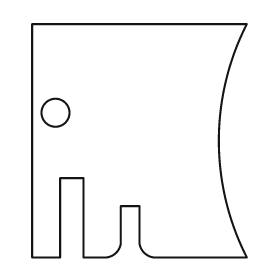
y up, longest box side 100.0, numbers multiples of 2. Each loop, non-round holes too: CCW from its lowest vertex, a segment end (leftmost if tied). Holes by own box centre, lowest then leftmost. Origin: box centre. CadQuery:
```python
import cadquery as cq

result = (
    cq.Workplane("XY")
    .moveTo(-46.0, -50.0)
    .lineTo(-34.0, -50.0)
    .lineTo(-34.0, -16.0)
    .lineTo(-24.0, -16.0)
    .lineTo(-24.0, -50.0)
    .lineTo(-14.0, -50.0)
    .threePointArc((-10.0, -48.0), (-8.0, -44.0))
    .lineTo(-8.0, -28.0)
    .lineTo(0.0, -28.0)
    .lineTo(0.0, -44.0)
    .threePointArc((2.0, -48.0), (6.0, -50.0))
    .lineTo(46.0, -50.0)
    .threePointArc((34.0, 0.0), (46.0, 50.0))
    .lineTo(-46.0, 50.0)
    .close()
    .moveTo(-36.0, 12.0)
    .circle(6.0)
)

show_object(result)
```